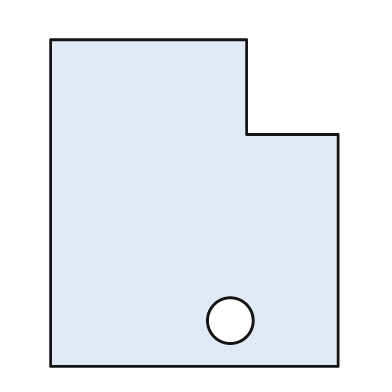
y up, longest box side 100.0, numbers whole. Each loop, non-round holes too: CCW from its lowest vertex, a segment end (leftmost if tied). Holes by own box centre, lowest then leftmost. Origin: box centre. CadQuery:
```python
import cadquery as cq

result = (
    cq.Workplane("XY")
    .moveTo(-44.0, -50.0)
    .lineTo(44.0, -50.0)
    .lineTo(44.0, 21.0)
    .lineTo(16.0, 21.0)
    .lineTo(16.0, 50.0)
    .lineTo(-44.0, 50.0)
    .close()
    .moveTo(11.0, -36.0)
    .circle(7.0)
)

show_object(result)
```